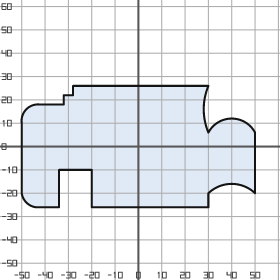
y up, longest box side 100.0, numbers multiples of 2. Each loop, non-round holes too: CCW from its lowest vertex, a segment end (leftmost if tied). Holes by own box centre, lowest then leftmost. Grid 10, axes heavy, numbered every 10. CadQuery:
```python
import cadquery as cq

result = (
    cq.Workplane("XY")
    .moveTo(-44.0, -26.0)
    .lineTo(-34.0, -26.0)
    .lineTo(-34.0, -10.0)
    .lineTo(-20.0, -10.0)
    .lineTo(-20.0, -26.0)
    .lineTo(30.0, -26.0)
    .lineTo(30.0, -20.0)
    .threePointArc((40.0, -16.0), (50.0, -20.0))
    .lineTo(50.0, 6.0)
    .threePointArc((40.0, 12.0), (30.0, 6.0))
    .threePointArc((28.0, 16.0), (30.0, 26.0))
    .lineTo(-28.0, 26.0)
    .lineTo(-28.0, 22.0)
    .lineTo(-32.0, 22.0)
    .lineTo(-32.0, 18.0)
    .lineTo(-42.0, 18.0)
    .threePointArc((-48.0, 16.0), (-50.0, 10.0))
    .lineTo(-50.0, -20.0)
    .threePointArc((-48.0, -24.0), (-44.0, -26.0))
    .close()
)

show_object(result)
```